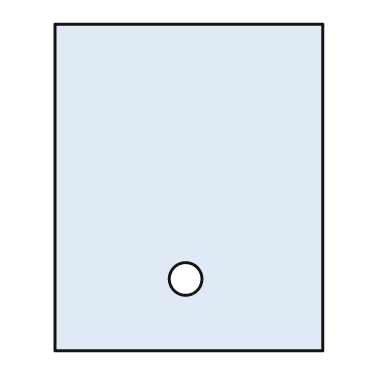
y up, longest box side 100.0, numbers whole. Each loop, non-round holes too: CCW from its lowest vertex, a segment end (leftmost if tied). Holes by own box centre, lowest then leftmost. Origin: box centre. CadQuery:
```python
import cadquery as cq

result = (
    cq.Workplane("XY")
    .moveTo(-41.0, -50.0)
    .lineTo(41.0, -50.0)
    .lineTo(41.0, 50.0)
    .lineTo(-41.0, 50.0)
    .close()
    .moveTo(-1.0, -28.0)
    .circle(5.0)
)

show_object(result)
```